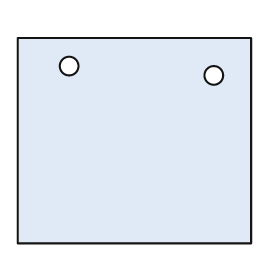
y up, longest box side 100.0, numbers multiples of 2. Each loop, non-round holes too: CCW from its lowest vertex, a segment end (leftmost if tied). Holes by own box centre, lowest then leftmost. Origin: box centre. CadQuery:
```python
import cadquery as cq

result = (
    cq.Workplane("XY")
    .moveTo(-50.0, -44.0)
    .lineTo(50.0, -44.0)
    .lineTo(50.0, 44.0)
    .lineTo(-50.0, 44.0)
    .close()
    .moveTo(34.0, 28.0)
    .circle(4.0)
    .moveTo(-28.0, 32.0)
    .circle(4.0)
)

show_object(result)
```